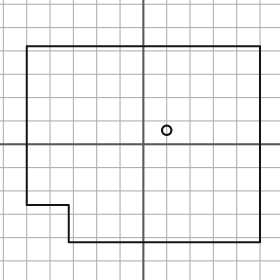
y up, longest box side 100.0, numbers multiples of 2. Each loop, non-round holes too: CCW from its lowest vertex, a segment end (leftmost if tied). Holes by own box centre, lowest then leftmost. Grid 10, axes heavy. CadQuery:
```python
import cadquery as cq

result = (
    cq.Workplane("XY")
    .moveTo(-32.0, -42.0)
    .lineTo(50.0, -42.0)
    .lineTo(50.0, 42.0)
    .lineTo(-50.0, 42.0)
    .lineTo(-50.0, -26.0)
    .lineTo(-32.0, -26.0)
    .close()
    .moveTo(10.0, 6.0)
    .circle(2.0)
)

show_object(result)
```